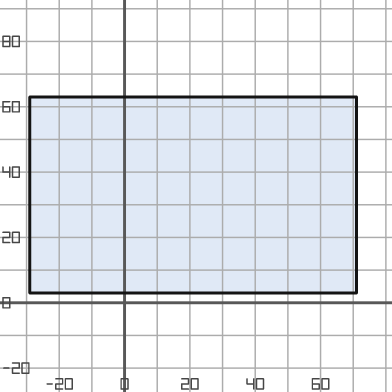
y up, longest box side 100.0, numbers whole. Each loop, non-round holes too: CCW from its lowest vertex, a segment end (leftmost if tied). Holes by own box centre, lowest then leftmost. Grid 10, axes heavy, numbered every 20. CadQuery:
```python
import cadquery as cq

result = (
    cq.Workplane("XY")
    .moveTo(-29.0, 3.0)
    .lineTo(71.0, 3.0)
    .lineTo(71.0, 63.0)
    .lineTo(-29.0, 63.0)
    .close()
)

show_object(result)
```